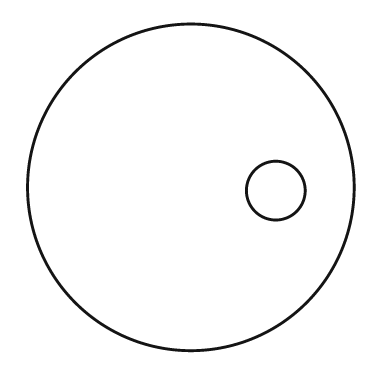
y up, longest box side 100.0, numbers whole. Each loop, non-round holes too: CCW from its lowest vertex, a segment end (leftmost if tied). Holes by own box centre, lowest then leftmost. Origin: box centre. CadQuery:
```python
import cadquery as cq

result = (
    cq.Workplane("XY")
    .moveTo(0.0, 0.0)
    .circle(50.0)
    .moveTo(26.0, -1.0)
    .circle(9.0)
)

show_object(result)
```